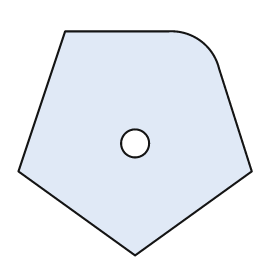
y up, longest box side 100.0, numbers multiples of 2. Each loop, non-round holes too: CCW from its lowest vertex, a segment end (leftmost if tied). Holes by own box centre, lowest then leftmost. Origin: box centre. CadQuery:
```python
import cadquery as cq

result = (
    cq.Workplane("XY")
    .moveTo(0.0, -48.0)
    .lineTo(50.0, -12.0)
    .lineTo(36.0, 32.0)
    .threePointArc((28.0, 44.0), (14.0, 48.0))
    .lineTo(-30.0, 48.0)
    .lineTo(-50.0, -12.0)
    .close()
    .moveTo(0.0, 0.0)
    .circle(6.0)
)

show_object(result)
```